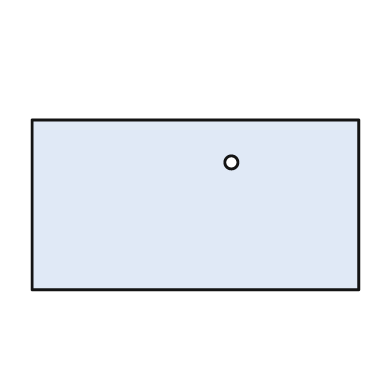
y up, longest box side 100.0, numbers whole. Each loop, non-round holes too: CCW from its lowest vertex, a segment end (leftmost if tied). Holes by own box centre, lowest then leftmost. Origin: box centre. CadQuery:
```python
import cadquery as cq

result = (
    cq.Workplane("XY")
    .moveTo(-50.0, -26.0)
    .lineTo(50.0, -26.0)
    .lineTo(50.0, 26.0)
    .lineTo(-50.0, 26.0)
    .close()
    .moveTo(11.0, 13.0)
    .circle(2.0)
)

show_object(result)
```